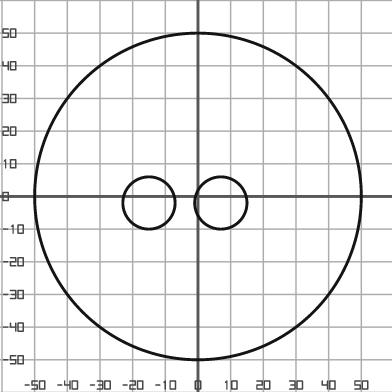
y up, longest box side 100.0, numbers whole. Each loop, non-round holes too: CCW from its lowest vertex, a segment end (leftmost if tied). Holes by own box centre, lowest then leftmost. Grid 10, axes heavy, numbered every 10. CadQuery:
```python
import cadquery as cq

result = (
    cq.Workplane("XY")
    .moveTo(0.0, 0.0)
    .circle(50.0)
    .moveTo(-15.0, -2.0)
    .circle(8.0)
    .moveTo(7.0, -2.0)
    .circle(8.0)
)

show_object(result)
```